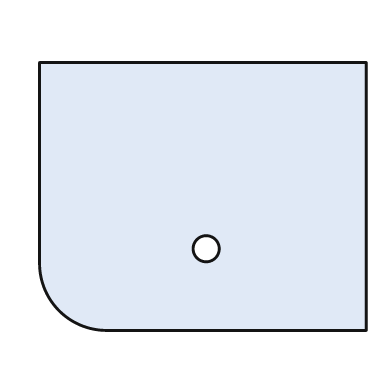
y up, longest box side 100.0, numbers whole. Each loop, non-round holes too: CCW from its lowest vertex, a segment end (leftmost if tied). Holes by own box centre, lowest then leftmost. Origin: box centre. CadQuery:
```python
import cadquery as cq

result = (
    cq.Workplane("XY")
    .moveTo(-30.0, -41.0)
    .lineTo(50.0, -41.0)
    .lineTo(50.0, 41.0)
    .lineTo(-50.0, 41.0)
    .lineTo(-50.0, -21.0)
    .threePointArc((-44.0, -35.0), (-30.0, -41.0))
    .close()
    .moveTo(1.0, -16.0)
    .circle(4.0)
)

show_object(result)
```